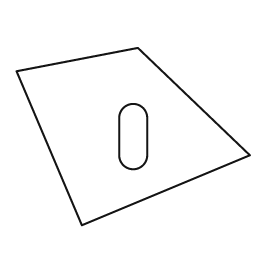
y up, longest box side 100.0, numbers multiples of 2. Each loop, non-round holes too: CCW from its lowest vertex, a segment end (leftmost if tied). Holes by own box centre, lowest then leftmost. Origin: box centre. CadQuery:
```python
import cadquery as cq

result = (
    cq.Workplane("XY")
    .moveTo(-22.0, -38.0)
    .lineTo(50.0, -8.0)
    .lineTo(2.0, 38.0)
    .lineTo(-50.0, 28.0)
    .close()
    .moveTo(-6.0, -8.0)
    .threePointArc((0.0, -14.0), (6.0, -8.0))
    .lineTo(6.0, 8.0)
    .threePointArc((0.0, 14.0), (-6.0, 8.0))
    .close()
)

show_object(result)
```